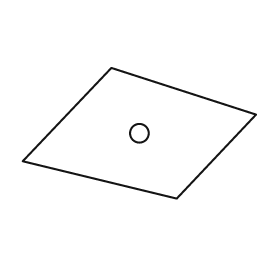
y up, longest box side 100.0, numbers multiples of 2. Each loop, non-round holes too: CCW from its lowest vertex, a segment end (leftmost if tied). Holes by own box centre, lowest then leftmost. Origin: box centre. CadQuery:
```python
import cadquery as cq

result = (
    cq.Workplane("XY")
    .moveTo(16.0, -28.0)
    .lineTo(50.0, 8.0)
    .lineTo(-12.0, 28.0)
    .lineTo(-50.0, -12.0)
    .close()
    .moveTo(0.0, 0.0)
    .circle(4.0)
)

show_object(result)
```